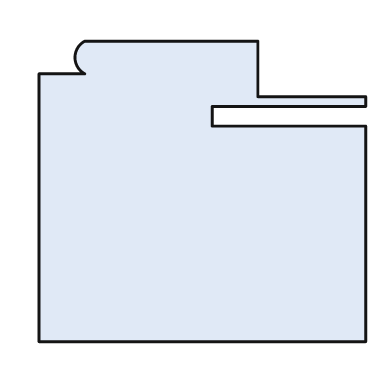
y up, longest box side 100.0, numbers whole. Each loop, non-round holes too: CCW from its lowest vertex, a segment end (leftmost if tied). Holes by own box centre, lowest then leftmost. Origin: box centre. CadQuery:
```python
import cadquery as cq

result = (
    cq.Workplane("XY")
    .moveTo(-50.0, -46.0)
    .lineTo(50.0, -46.0)
    .lineTo(50.0, 20.0)
    .lineTo(3.0, 20.0)
    .lineTo(3.0, 26.0)
    .lineTo(50.0, 26.0)
    .lineTo(50.0, 29.0)
    .lineTo(17.0, 29.0)
    .lineTo(17.0, 46.0)
    .lineTo(-36.0, 46.0)
    .threePointArc((-39.0, 41.0), (-36.0, 36.0))
    .lineTo(-50.0, 36.0)
    .close()
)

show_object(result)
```